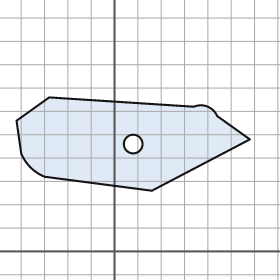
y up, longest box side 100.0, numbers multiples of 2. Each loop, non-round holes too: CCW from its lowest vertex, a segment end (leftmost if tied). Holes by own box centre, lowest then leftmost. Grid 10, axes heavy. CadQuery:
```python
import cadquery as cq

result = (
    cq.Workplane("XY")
    .moveTo(16.0, 26.0)
    .lineTo(58.0, 48.0)
    .lineTo(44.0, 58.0)
    .threePointArc((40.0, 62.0), (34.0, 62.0))
    .lineTo(-28.0, 66.0)
    .lineTo(-42.0, 56.0)
    .lineTo(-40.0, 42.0)
    .threePointArc((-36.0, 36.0), (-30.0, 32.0))
    .close()
    .moveTo(8.0, 46.0)
    .circle(4.0)
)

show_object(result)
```